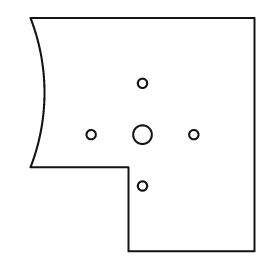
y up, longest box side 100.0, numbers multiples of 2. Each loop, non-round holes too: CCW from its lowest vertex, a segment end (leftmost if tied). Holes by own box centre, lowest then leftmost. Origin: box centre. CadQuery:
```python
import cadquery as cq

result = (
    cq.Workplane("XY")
    .moveTo(-6.0, -50.0)
    .lineTo(48.0, -50.0)
    .lineTo(48.0, 50.0)
    .lineTo(-48.0, 50.0)
    .threePointArc((-42.0, 18.0), (-48.0, -14.0))
    .lineTo(-6.0, -14.0)
    .close()
    .moveTo(0.0, -22.0)
    .circle(2.0)
    .moveTo(-22.0, 0.0)
    .circle(2.0)
    .moveTo(0.0, 0.0)
    .circle(4.0)
    .moveTo(22.0, 0.0)
    .circle(2.0)
    .moveTo(0.0, 22.0)
    .circle(2.0)
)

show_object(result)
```